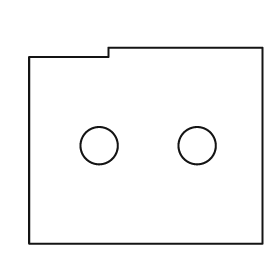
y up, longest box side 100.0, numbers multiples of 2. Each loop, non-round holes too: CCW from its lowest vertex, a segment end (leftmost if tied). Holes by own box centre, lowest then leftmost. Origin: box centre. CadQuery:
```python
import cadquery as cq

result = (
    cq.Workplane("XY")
    .moveTo(-50.0, -42.0)
    .lineTo(50.0, -42.0)
    .lineTo(50.0, 42.0)
    .lineTo(-16.0, 42.0)
    .lineTo(-16.0, 38.0)
    .lineTo(-50.0, 38.0)
    .close()
    .moveTo(-20.0, 0.0)
    .circle(8.0)
    .moveTo(22.0, 0.0)
    .circle(8.0)
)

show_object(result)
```